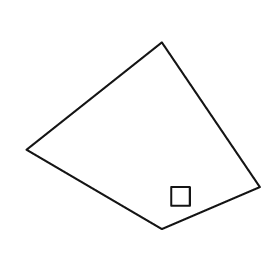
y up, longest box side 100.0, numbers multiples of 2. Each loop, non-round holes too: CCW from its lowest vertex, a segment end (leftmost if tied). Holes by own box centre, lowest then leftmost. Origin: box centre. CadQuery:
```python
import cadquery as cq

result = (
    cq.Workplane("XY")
    .moveTo(8.0, -40.0)
    .lineTo(50.0, -22.0)
    .lineTo(8.0, 40.0)
    .lineTo(-50.0, -6.0)
    .close()
    .moveTo(12.0, -30.0)
    .lineTo(20.0, -30.0)
    .lineTo(20.0, -22.0)
    .lineTo(12.0, -22.0)
    .close()
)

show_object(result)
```